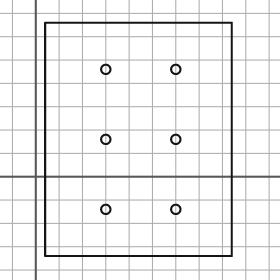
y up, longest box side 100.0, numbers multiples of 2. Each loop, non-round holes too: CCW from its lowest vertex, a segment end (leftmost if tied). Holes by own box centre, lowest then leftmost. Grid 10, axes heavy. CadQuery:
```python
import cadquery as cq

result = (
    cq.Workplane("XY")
    .moveTo(4.0, -34.0)
    .lineTo(84.0, -34.0)
    .lineTo(84.0, 66.0)
    .lineTo(4.0, 66.0)
    .close()
    .moveTo(30.0, -14.0)
    .circle(2.0)
    .moveTo(60.0, -14.0)
    .circle(2.0)
    .moveTo(30.0, 16.0)
    .circle(2.0)
    .moveTo(60.0, 16.0)
    .circle(2.0)
    .moveTo(30.0, 46.0)
    .circle(2.0)
    .moveTo(60.0, 46.0)
    .circle(2.0)
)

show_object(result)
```